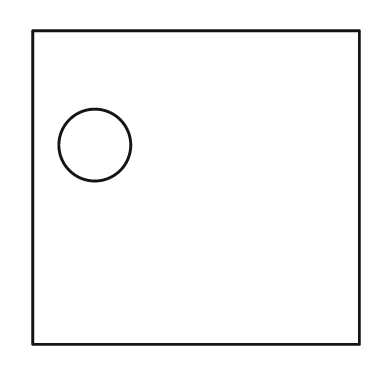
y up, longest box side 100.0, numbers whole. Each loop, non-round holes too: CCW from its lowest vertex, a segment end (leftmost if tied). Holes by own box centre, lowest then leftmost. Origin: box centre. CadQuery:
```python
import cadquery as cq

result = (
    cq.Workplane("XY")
    .moveTo(-50.0, -48.0)
    .lineTo(50.0, -48.0)
    .lineTo(50.0, 48.0)
    .lineTo(-50.0, 48.0)
    .close()
    .moveTo(-31.0, 13.0)
    .circle(11.0)
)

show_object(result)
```